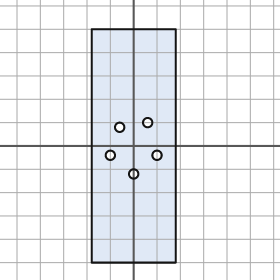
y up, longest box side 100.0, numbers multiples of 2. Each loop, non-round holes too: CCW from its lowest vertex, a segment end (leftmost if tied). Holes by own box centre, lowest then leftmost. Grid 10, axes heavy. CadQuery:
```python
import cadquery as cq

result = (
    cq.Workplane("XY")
    .moveTo(-18.0, -50.0)
    .lineTo(18.0, -50.0)
    .lineTo(18.0, 50.0)
    .lineTo(-18.0, 50.0)
    .close()
    .moveTo(0.0, -12.0)
    .circle(2.0)
    .moveTo(-10.0, -4.0)
    .circle(2.0)
    .moveTo(10.0, -4.0)
    .circle(2.0)
    .moveTo(-6.0, 8.0)
    .circle(2.0)
    .moveTo(6.0, 10.0)
    .circle(2.0)
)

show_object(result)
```